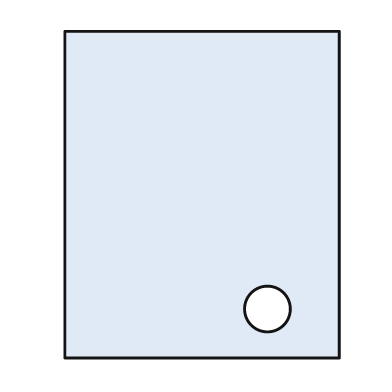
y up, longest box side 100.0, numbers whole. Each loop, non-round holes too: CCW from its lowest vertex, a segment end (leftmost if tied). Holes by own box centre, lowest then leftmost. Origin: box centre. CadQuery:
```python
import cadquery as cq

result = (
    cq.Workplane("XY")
    .moveTo(-42.0, -50.0)
    .lineTo(42.0, -50.0)
    .lineTo(42.0, 50.0)
    .lineTo(-42.0, 50.0)
    .close()
    .moveTo(20.0, -35.0)
    .circle(7.0)
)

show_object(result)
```